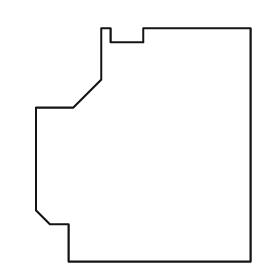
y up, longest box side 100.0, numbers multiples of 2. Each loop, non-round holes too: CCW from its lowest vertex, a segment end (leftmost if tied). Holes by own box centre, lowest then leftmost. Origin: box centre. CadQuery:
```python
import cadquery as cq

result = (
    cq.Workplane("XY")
    .moveTo(-32.0, -50.0)
    .lineTo(46.0, -50.0)
    .lineTo(46.0, 50.0)
    .lineTo(0.0, 50.0)
    .lineTo(0.0, 44.0)
    .lineTo(-14.0, 44.0)
    .lineTo(-14.0, 50.0)
    .lineTo(-18.0, 50.0)
    .lineTo(-18.0, 28.0)
    .lineTo(-30.0, 16.0)
    .lineTo(-46.0, 16.0)
    .lineTo(-46.0, -28.0)
    .lineTo(-40.0, -34.0)
    .lineTo(-32.0, -34.0)
    .close()
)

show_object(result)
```